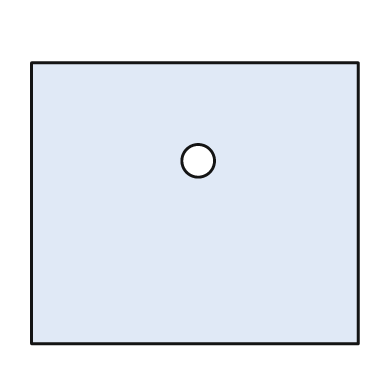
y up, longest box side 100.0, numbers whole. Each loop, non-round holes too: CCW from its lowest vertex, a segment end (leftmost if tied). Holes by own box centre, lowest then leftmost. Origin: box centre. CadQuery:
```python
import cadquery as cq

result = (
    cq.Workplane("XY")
    .moveTo(-50.0, -43.0)
    .lineTo(50.0, -43.0)
    .lineTo(50.0, 43.0)
    .lineTo(-50.0, 43.0)
    .close()
    .moveTo(1.0, 13.0)
    .circle(5.0)
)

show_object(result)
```